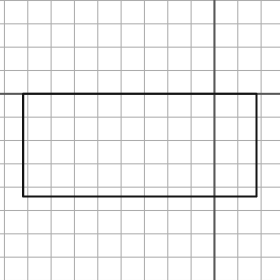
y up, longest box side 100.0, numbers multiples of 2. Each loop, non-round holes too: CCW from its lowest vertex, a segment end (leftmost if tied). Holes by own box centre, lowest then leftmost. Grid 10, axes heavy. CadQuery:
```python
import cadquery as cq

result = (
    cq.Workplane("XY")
    .moveTo(-82.0, -44.0)
    .lineTo(18.0, -44.0)
    .lineTo(18.0, 0.0)
    .lineTo(-82.0, 0.0)
    .close()
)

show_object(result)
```